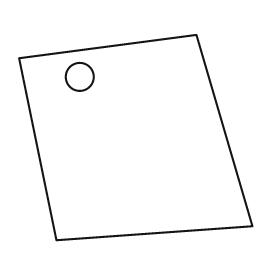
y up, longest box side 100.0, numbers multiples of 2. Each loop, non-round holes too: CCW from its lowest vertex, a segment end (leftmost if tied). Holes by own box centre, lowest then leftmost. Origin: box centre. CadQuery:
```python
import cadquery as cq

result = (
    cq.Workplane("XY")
    .moveTo(-34.0, -44.0)
    .lineTo(50.0, -38.0)
    .lineTo(26.0, 44.0)
    .lineTo(-50.0, 34.0)
    .close()
    .moveTo(-24.0, 26.0)
    .circle(6.0)
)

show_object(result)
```